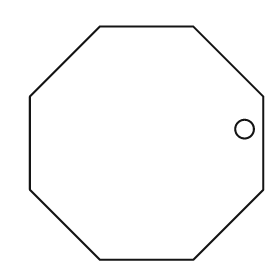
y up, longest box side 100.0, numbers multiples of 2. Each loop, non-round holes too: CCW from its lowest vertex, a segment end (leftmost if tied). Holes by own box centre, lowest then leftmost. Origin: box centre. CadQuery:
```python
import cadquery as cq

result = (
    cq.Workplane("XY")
    .moveTo(-20.0, -50.0)
    .lineTo(20.0, -50.0)
    .lineTo(50.0, -20.0)
    .lineTo(50.0, 20.0)
    .lineTo(20.0, 50.0)
    .lineTo(-20.0, 50.0)
    .lineTo(-50.0, 20.0)
    .lineTo(-50.0, -20.0)
    .close()
    .moveTo(42.0, 6.0)
    .circle(4.0)
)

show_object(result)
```